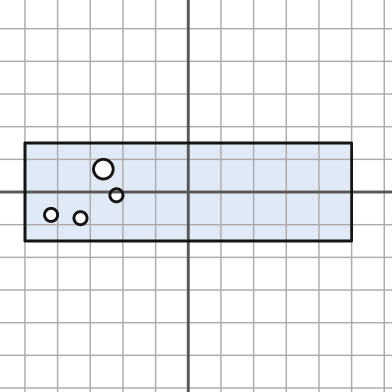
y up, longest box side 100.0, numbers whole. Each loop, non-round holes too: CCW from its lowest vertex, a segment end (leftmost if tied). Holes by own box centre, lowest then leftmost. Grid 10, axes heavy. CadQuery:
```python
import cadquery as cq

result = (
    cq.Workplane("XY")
    .moveTo(-50.0, -15.0)
    .lineTo(50.0, -15.0)
    .lineTo(50.0, 15.0)
    .lineTo(-50.0, 15.0)
    .close()
    .moveTo(-33.0, -8.0)
    .circle(2.0)
    .moveTo(-42.0, -7.0)
    .circle(2.0)
    .moveTo(-22.0, -1.0)
    .circle(2.0)
    .moveTo(-26.0, 7.0)
    .circle(3.0)
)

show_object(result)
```